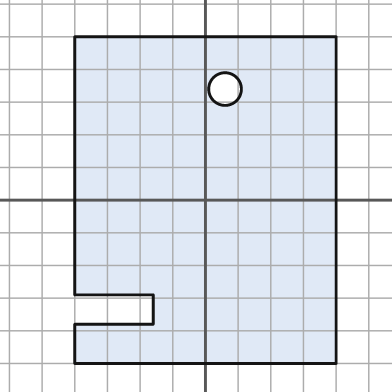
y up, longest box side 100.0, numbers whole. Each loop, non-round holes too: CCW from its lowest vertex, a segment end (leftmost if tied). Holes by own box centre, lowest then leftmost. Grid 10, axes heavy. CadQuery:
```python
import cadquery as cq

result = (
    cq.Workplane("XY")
    .moveTo(-40.0, -50.0)
    .lineTo(40.0, -50.0)
    .lineTo(40.0, 50.0)
    .lineTo(-40.0, 50.0)
    .lineTo(-40.0, -29.0)
    .lineTo(-16.0, -29.0)
    .lineTo(-16.0, -38.0)
    .lineTo(-40.0, -38.0)
    .close()
    .moveTo(6.0, 34.0)
    .circle(5.0)
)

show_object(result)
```